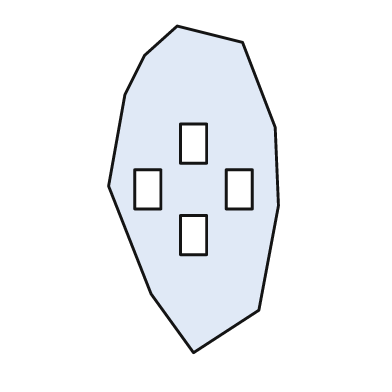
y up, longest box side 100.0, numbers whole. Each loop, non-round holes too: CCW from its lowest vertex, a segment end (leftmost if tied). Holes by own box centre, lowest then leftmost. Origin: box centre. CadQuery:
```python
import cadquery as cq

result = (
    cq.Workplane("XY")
    .moveTo(0.0, -50.0)
    .lineTo(20.0, -37.0)
    .lineTo(26.0, -5.0)
    .lineTo(25.0, 19.0)
    .lineTo(15.0, 45.0)
    .lineTo(-5.0, 50.0)
    .lineTo(-15.0, 41.0)
    .lineTo(-21.0, 29.0)
    .lineTo(-26.0, 1.0)
    .lineTo(-13.0, -32.0)
    .close()
    .moveTo(-4.0, -20.0)
    .lineTo(4.0, -20.0)
    .lineTo(4.0, -8.0)
    .lineTo(-4.0, -8.0)
    .close()
    .moveTo(-18.0, -6.0)
    .lineTo(-10.0, -6.0)
    .lineTo(-10.0, 6.0)
    .lineTo(-18.0, 6.0)
    .close()
    .moveTo(10.0, -6.0)
    .lineTo(18.0, -6.0)
    .lineTo(18.0, 6.0)
    .lineTo(10.0, 6.0)
    .close()
    .moveTo(-4.0, 8.0)
    .lineTo(4.0, 8.0)
    .lineTo(4.0, 20.0)
    .lineTo(-4.0, 20.0)
    .close()
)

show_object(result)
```